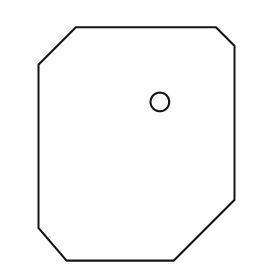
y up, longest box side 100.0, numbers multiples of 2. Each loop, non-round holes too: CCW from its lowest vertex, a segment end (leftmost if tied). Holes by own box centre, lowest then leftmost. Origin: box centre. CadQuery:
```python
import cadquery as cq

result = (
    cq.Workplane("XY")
    .moveTo(-30.0, -50.0)
    .lineTo(16.0, -50.0)
    .lineTo(42.0, -24.0)
    .lineTo(42.0, 42.0)
    .lineTo(34.0, 50.0)
    .lineTo(-26.0, 50.0)
    .lineTo(-42.0, 34.0)
    .lineTo(-42.0, -36.0)
    .close()
    .moveTo(10.0, 18.0)
    .circle(4.0)
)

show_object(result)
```